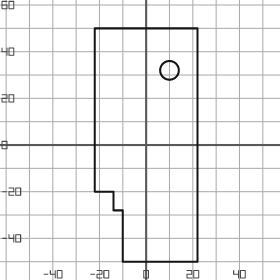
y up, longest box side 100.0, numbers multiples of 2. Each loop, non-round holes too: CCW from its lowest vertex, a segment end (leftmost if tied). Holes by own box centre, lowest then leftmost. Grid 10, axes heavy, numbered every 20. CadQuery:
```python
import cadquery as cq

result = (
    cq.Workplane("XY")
    .moveTo(-10.0, -50.0)
    .lineTo(22.0, -50.0)
    .lineTo(22.0, 50.0)
    .lineTo(-22.0, 50.0)
    .lineTo(-22.0, -20.0)
    .lineTo(-14.0, -20.0)
    .lineTo(-14.0, -28.0)
    .lineTo(-10.0, -28.0)
    .close()
    .moveTo(10.0, 32.0)
    .circle(4.0)
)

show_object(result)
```